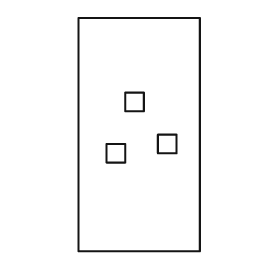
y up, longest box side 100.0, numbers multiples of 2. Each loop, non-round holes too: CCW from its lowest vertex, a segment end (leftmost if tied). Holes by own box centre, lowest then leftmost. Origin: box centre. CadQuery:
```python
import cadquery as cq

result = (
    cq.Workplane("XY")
    .moveTo(-26.0, -50.0)
    .lineTo(26.0, -50.0)
    .lineTo(26.0, 50.0)
    .lineTo(-26.0, 50.0)
    .close()
    .moveTo(-14.0, -12.0)
    .lineTo(-6.0, -12.0)
    .lineTo(-6.0, -4.0)
    .lineTo(-14.0, -4.0)
    .close()
    .moveTo(8.0, -8.0)
    .lineTo(16.0, -8.0)
    .lineTo(16.0, 0.0)
    .lineTo(8.0, 0.0)
    .close()
    .moveTo(-6.0, 10.0)
    .lineTo(2.0, 10.0)
    .lineTo(2.0, 18.0)
    .lineTo(-6.0, 18.0)
    .close()
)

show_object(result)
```